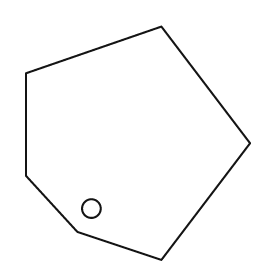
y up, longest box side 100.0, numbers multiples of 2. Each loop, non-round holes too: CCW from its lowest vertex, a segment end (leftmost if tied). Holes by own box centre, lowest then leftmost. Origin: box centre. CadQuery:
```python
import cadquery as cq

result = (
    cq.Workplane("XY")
    .moveTo(10.0, -50.0)
    .lineTo(48.0, 0.0)
    .lineTo(10.0, 50.0)
    .lineTo(-48.0, 30.0)
    .lineTo(-48.0, -14.0)
    .lineTo(-26.0, -38.0)
    .close()
    .moveTo(-20.0, -28.0)
    .circle(4.0)
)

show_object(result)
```